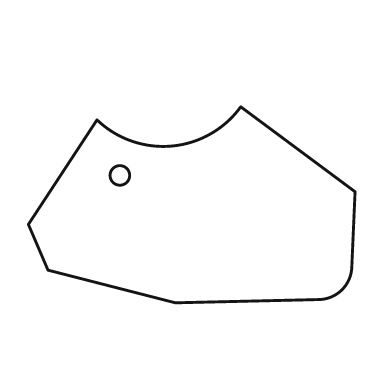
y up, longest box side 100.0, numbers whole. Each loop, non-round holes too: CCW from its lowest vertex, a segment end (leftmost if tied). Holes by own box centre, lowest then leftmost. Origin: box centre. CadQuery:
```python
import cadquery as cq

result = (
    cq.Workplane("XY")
    .moveTo(-5.0, -30.0)
    .lineTo(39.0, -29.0)
    .threePointArc((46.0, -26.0), (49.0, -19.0))
    .lineTo(50.0, 4.0)
    .lineTo(15.0, 30.0)
    .threePointArc((-6.0, 18.0), (-29.0, 26.0))
    .lineTo(-50.0, -6.0)
    .lineTo(-44.0, -20.0)
    .close()
    .moveTo(-22.0, 9.0)
    .circle(3.0)
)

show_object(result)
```